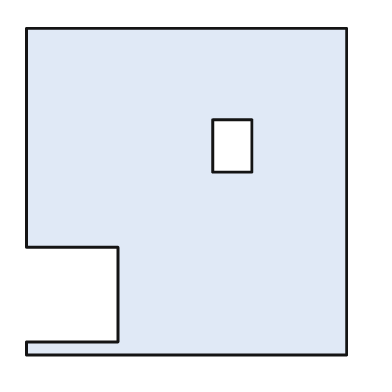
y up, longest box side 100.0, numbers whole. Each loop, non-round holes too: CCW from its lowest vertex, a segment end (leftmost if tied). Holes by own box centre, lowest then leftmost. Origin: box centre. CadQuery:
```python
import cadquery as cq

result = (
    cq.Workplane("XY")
    .moveTo(-49.0, -50.0)
    .lineTo(49.0, -50.0)
    .lineTo(49.0, 50.0)
    .lineTo(-49.0, 50.0)
    .lineTo(-49.0, -17.0)
    .lineTo(-21.0, -17.0)
    .lineTo(-21.0, -46.0)
    .lineTo(-49.0, -46.0)
    .close()
    .moveTo(8.0, 6.0)
    .lineTo(20.0, 6.0)
    .lineTo(20.0, 22.0)
    .lineTo(8.0, 22.0)
    .close()
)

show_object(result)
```